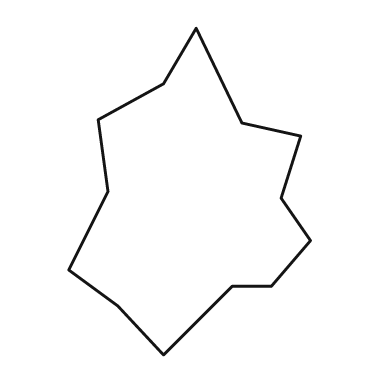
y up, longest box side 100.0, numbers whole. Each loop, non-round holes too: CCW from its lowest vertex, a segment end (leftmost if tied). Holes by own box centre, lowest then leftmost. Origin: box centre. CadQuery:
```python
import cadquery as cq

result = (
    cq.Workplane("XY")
    .moveTo(-8.0, -50.0)
    .lineTo(13.0, -29.0)
    .lineTo(25.0, -29.0)
    .lineTo(37.0, -15.0)
    .lineTo(28.0, -2.0)
    .lineTo(34.0, 17.0)
    .lineTo(16.0, 21.0)
    .lineTo(2.0, 50.0)
    .lineTo(-8.0, 33.0)
    .lineTo(-28.0, 22.0)
    .lineTo(-25.0, 0.0)
    .lineTo(-37.0, -24.0)
    .lineTo(-22.0, -35.0)
    .close()
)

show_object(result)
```